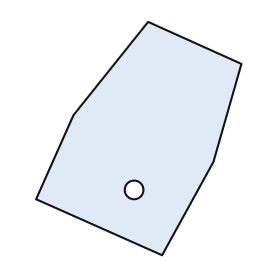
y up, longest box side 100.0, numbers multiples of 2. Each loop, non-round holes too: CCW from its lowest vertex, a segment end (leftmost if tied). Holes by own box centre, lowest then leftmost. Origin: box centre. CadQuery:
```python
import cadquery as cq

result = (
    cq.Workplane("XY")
    .moveTo(10.0, -50.0)
    .lineTo(32.0, -10.0)
    .lineTo(44.0, 32.0)
    .lineTo(4.0, 50.0)
    .lineTo(-28.0, 10.0)
    .lineTo(-44.0, -26.0)
    .close()
    .moveTo(-2.0, -22.0)
    .circle(4.0)
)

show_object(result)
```